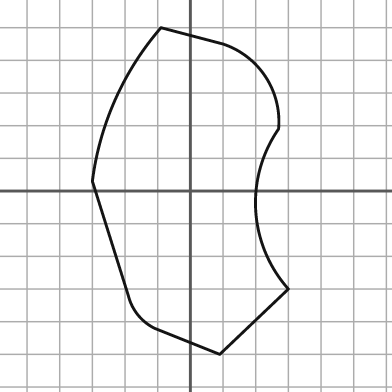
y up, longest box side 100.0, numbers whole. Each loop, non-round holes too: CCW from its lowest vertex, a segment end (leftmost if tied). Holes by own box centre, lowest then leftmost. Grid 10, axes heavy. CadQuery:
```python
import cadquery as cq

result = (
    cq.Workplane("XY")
    .moveTo(9.0, -50.0)
    .lineTo(30.0, -30.0)
    .threePointArc((20.0, -6.0), (27.0, 19.0))
    .threePointArc((23.0, 35.0), (10.0, 45.0))
    .lineTo(-9.0, 50.0)
    .threePointArc((-23.0, 28.0), (-30.0, 3.0))
    .lineTo(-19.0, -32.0)
    .threePointArc((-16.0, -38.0), (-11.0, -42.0))
    .close()
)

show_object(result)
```